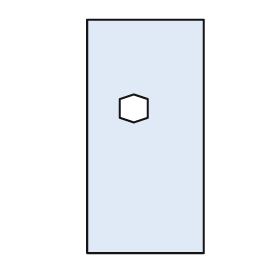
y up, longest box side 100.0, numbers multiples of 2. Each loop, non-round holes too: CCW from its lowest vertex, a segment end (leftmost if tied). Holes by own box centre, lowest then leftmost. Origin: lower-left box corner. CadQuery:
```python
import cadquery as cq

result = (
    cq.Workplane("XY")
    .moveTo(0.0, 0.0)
    .lineTo(50.0, 0.0)
    .lineTo(50.0, 100.0)
    .lineTo(0.0, 100.0)
    .close()
    .moveTo(20.0, 56.0)
    .lineTo(26.0, 58.0)
    .lineTo(26.0, 66.0)
    .lineTo(20.0, 68.0)
    .lineTo(14.0, 66.0)
    .lineTo(14.0, 58.0)
    .close()
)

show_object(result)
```